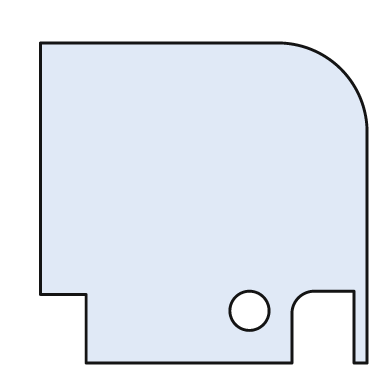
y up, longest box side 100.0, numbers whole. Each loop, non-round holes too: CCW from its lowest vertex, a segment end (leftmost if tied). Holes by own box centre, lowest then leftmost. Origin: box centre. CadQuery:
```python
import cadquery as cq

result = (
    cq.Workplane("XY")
    .moveTo(-36.0, -49.0)
    .lineTo(27.0, -49.0)
    .lineTo(27.0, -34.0)
    .threePointArc((29.0, -29.0), (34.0, -27.0))
    .lineTo(46.0, -27.0)
    .lineTo(46.0, -49.0)
    .lineTo(50.0, -49.0)
    .lineTo(50.0, 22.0)
    .threePointArc((42.0, 41.0), (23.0, 49.0))
    .lineTo(-50.0, 49.0)
    .lineTo(-50.0, -28.0)
    .lineTo(-36.0, -28.0)
    .close()
    .moveTo(14.0, -33.0)
    .circle(6.0)
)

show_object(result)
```